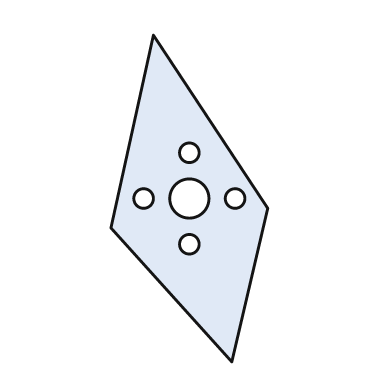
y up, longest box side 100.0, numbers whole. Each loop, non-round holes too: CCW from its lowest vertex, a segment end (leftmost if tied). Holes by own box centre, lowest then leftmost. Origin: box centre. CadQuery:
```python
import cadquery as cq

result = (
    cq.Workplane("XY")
    .moveTo(13.0, -50.0)
    .lineTo(24.0, -3.0)
    .lineTo(-11.0, 50.0)
    .lineTo(-24.0, -9.0)
    .close()
    .moveTo(0.0, -14.0)
    .circle(3.0)
    .moveTo(-14.0, 0.0)
    .circle(3.0)
    .moveTo(0.0, 0.0)
    .circle(6.0)
    .moveTo(14.0, 0.0)
    .circle(3.0)
    .moveTo(0.0, 14.0)
    .circle(3.0)
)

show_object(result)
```